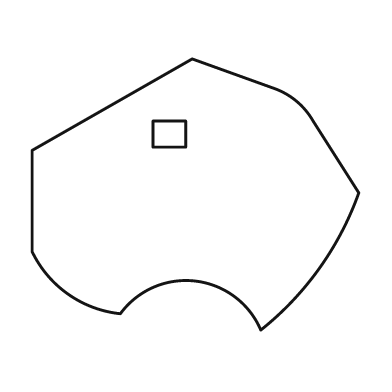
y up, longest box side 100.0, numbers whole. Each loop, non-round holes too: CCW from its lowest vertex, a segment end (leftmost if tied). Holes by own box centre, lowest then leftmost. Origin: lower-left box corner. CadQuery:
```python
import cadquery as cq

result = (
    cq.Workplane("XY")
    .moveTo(70.0, 0.0)
    .threePointArc((88.0, 19.0), (100.0, 42.0))
    .lineTo(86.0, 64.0)
    .threePointArc((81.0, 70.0), (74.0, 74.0))
    .lineTo(49.0, 83.0)
    .lineTo(0.0, 55.0)
    .lineTo(0.0, 24.0)
    .threePointArc((11.0, 11.0), (27.0, 5.0))
    .threePointArc((50.0, 15.0), (70.0, 0.0))
    .close()
    .moveTo(37.0, 56.0)
    .lineTo(47.0, 56.0)
    .lineTo(47.0, 64.0)
    .lineTo(37.0, 64.0)
    .close()
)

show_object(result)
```